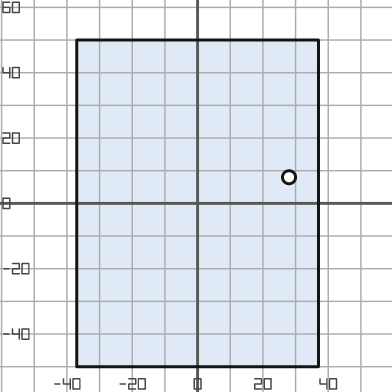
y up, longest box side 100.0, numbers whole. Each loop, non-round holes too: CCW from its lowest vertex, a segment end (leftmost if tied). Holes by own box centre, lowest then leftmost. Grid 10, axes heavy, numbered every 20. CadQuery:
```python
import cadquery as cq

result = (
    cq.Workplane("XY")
    .moveTo(-37.0, -50.0)
    .lineTo(37.0, -50.0)
    .lineTo(37.0, 50.0)
    .lineTo(-37.0, 50.0)
    .close()
    .moveTo(28.0, 8.0)
    .circle(2.0)
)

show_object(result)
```